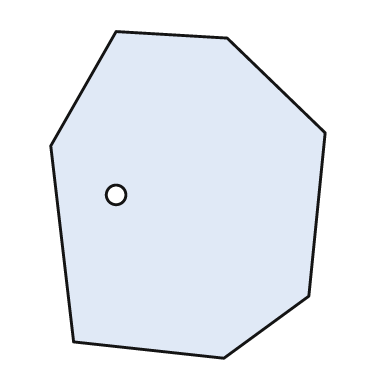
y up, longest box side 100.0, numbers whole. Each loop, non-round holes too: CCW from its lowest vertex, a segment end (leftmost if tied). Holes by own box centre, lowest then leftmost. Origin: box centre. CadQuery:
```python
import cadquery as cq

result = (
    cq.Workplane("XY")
    .moveTo(11.0, -50.0)
    .lineTo(37.0, -31.0)
    .lineTo(42.0, 19.0)
    .lineTo(12.0, 48.0)
    .lineTo(-22.0, 50.0)
    .lineTo(-42.0, 15.0)
    .lineTo(-35.0, -45.0)
    .close()
    .moveTo(-22.0, 0.0)
    .circle(3.0)
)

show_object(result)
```